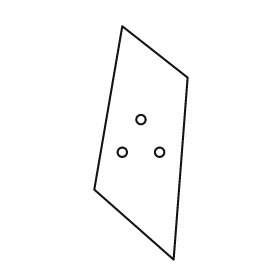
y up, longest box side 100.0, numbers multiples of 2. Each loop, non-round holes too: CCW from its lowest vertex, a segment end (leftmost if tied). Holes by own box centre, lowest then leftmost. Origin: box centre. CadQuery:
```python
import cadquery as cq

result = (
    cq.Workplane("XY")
    .moveTo(14.0, -50.0)
    .lineTo(20.0, 28.0)
    .lineTo(-8.0, 50.0)
    .lineTo(-20.0, -20.0)
    .close()
    .moveTo(-8.0, -4.0)
    .circle(2.0)
    .moveTo(8.0, -4.0)
    .circle(2.0)
    .moveTo(0.0, 10.0)
    .circle(2.0)
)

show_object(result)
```